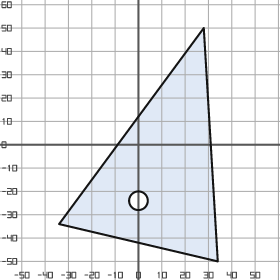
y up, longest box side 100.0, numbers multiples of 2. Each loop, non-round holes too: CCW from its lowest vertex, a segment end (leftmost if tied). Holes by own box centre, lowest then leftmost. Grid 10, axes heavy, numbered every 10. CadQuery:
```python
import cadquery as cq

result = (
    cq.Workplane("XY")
    .moveTo(34.0, -50.0)
    .lineTo(28.0, 50.0)
    .lineTo(-34.0, -34.0)
    .close()
    .moveTo(0.0, -24.0)
    .circle(4.0)
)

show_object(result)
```